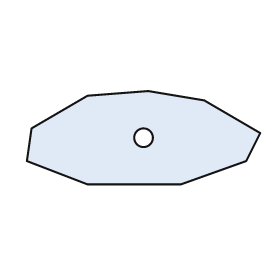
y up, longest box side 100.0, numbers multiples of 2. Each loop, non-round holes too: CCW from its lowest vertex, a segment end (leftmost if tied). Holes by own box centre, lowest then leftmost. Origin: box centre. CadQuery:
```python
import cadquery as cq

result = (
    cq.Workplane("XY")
    .moveTo(-24.0, -20.0)
    .lineTo(16.0, -20.0)
    .lineTo(44.0, -10.0)
    .lineTo(50.0, 2.0)
    .lineTo(26.0, 16.0)
    .lineTo(2.0, 20.0)
    .lineTo(-24.0, 18.0)
    .lineTo(-48.0, 4.0)
    .lineTo(-50.0, -10.0)
    .close()
    .moveTo(0.0, 0.0)
    .circle(4.0)
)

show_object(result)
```